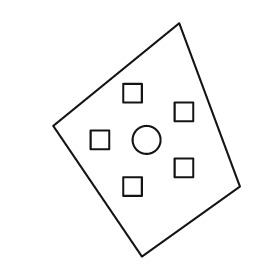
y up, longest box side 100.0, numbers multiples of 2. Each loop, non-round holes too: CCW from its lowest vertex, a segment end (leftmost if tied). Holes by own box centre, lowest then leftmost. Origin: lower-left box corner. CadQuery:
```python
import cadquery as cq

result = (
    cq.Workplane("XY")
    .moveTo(38.0, 0.0)
    .lineTo(80.0, 30.0)
    .lineTo(54.0, 100.0)
    .lineTo(0.0, 56.0)
    .close()
    .moveTo(30.0, 26.0)
    .lineTo(38.0, 26.0)
    .lineTo(38.0, 34.0)
    .lineTo(30.0, 34.0)
    .close()
    .moveTo(52.0, 34.0)
    .lineTo(60.0, 34.0)
    .lineTo(60.0, 42.0)
    .lineTo(52.0, 42.0)
    .close()
    .moveTo(16.0, 46.0)
    .lineTo(24.0, 46.0)
    .lineTo(24.0, 54.0)
    .lineTo(16.0, 54.0)
    .close()
    .moveTo(40.0, 50.0)
    .circle(6.0)
    .moveTo(52.0, 58.0)
    .lineTo(60.0, 58.0)
    .lineTo(60.0, 66.0)
    .lineTo(52.0, 66.0)
    .close()
    .moveTo(30.0, 66.0)
    .lineTo(38.0, 66.0)
    .lineTo(38.0, 74.0)
    .lineTo(30.0, 74.0)
    .close()
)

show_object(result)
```